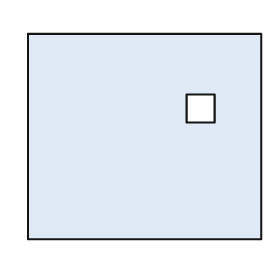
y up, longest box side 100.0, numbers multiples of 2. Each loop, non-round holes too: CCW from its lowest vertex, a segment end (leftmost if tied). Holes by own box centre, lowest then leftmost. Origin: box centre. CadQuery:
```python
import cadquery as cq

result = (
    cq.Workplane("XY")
    .moveTo(-50.0, -44.0)
    .lineTo(50.0, -44.0)
    .lineTo(50.0, 44.0)
    .lineTo(-50.0, 44.0)
    .close()
    .moveTo(18.0, 6.0)
    .lineTo(30.0, 6.0)
    .lineTo(30.0, 18.0)
    .lineTo(18.0, 18.0)
    .close()
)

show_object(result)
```